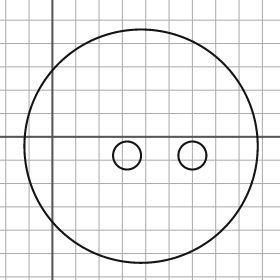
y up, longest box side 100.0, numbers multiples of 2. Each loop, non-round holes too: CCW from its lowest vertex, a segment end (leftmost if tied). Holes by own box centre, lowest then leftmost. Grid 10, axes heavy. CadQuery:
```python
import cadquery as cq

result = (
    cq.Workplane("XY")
    .moveTo(38.0, -4.0)
    .circle(50.0)
    .moveTo(32.0, -8.0)
    .circle(6.0)
    .moveTo(60.0, -8.0)
    .circle(6.0)
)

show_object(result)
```